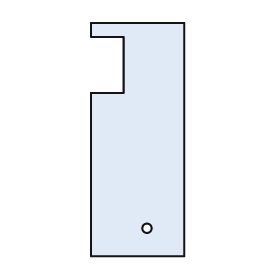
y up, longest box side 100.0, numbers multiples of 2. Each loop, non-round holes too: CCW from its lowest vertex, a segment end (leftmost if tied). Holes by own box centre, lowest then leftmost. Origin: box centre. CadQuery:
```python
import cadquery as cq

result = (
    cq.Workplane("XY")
    .moveTo(-20.0, -50.0)
    .lineTo(20.0, -50.0)
    .lineTo(20.0, 50.0)
    .lineTo(-20.0, 50.0)
    .lineTo(-20.0, 44.0)
    .lineTo(-6.0, 44.0)
    .lineTo(-6.0, 20.0)
    .lineTo(-20.0, 20.0)
    .close()
    .moveTo(4.0, -38.0)
    .circle(2.0)
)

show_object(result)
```